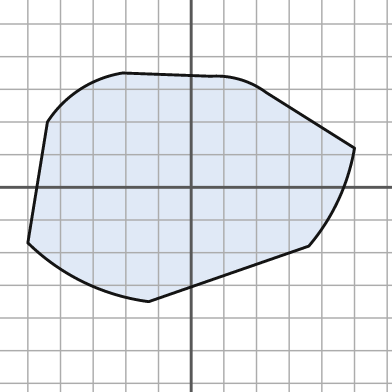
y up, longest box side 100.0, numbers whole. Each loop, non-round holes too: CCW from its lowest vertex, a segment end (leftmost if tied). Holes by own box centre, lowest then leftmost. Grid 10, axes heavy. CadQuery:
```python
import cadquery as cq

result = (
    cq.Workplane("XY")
    .moveTo(-13.0, -35.0)
    .lineTo(36.0, -18.0)
    .threePointArc((45.0, -4.0), (50.0, 12.0))
    .lineTo(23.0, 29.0)
    .threePointArc((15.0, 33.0), (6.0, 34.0))
    .lineTo(-21.0, 35.0)
    .threePointArc((-34.0, 30.0), (-44.0, 20.0))
    .lineTo(-50.0, -17.0)
    .threePointArc((-33.0, -29.0), (-13.0, -35.0))
    .close()
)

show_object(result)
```